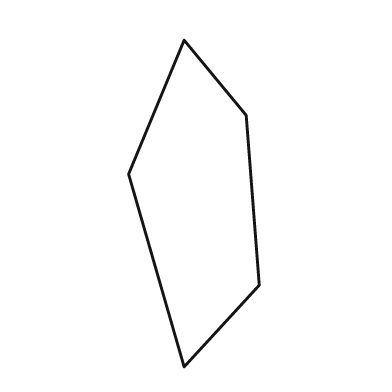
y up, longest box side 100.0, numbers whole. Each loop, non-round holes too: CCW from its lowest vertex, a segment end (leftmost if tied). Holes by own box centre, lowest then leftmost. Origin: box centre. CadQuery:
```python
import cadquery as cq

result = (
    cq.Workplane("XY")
    .moveTo(-3.0, -50.0)
    .lineTo(20.0, -25.0)
    .lineTo(16.0, 27.0)
    .lineTo(-3.0, 50.0)
    .lineTo(-20.0, 9.0)
    .close()
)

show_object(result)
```